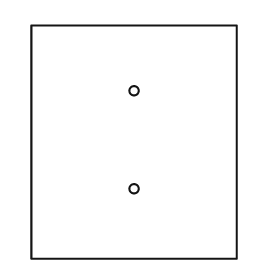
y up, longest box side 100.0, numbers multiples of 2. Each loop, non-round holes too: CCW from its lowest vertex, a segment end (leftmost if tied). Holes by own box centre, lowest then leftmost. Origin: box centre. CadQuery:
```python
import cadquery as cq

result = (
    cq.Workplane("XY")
    .moveTo(-44.0, -50.0)
    .lineTo(44.0, -50.0)
    .lineTo(44.0, 50.0)
    .lineTo(-44.0, 50.0)
    .close()
    .moveTo(0.0, -20.0)
    .circle(2.0)
    .moveTo(0.0, 22.0)
    .circle(2.0)
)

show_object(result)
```